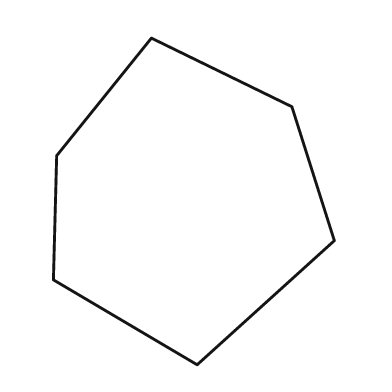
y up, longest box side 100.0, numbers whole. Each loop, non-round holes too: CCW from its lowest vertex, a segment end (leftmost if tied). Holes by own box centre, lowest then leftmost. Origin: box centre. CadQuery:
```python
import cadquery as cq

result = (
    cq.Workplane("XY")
    .moveTo(1.0, -50.0)
    .lineTo(43.0, -12.0)
    .lineTo(30.0, 29.0)
    .lineTo(-13.0, 50.0)
    .lineTo(-42.0, 14.0)
    .lineTo(-43.0, -24.0)
    .close()
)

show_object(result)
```